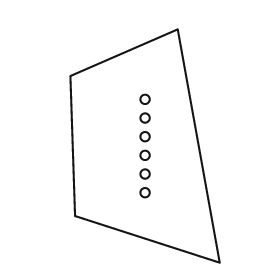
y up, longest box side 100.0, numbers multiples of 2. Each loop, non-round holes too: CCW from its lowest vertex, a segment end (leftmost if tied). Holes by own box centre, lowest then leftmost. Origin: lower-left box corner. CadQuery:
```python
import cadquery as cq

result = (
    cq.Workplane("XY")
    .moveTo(64.0, 0.0)
    .lineTo(46.0, 100.0)
    .lineTo(0.0, 80.0)
    .lineTo(2.0, 20.0)
    .close()
    .moveTo(32.0, 30.0)
    .circle(2.0)
    .moveTo(32.0, 38.0)
    .circle(2.0)
    .moveTo(32.0, 46.0)
    .circle(2.0)
    .moveTo(32.0, 54.0)
    .circle(2.0)
    .moveTo(32.0, 62.0)
    .circle(2.0)
    .moveTo(32.0, 70.0)
    .circle(2.0)
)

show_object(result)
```